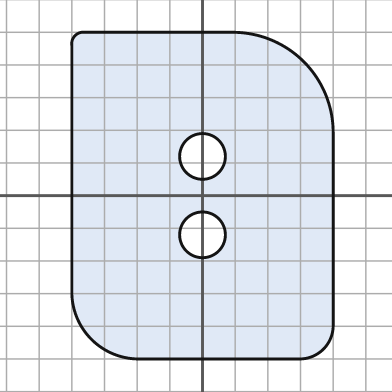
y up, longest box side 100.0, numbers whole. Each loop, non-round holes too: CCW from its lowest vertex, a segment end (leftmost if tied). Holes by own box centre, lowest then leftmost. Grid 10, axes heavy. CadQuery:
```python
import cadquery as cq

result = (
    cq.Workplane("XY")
    .moveTo(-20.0, -50.0)
    .lineTo(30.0, -50.0)
    .threePointArc((37.0, -47.0), (40.0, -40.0))
    .lineTo(40.0, 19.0)
    .threePointArc((31.0, 41.0), (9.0, 50.0))
    .lineTo(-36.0, 50.0)
    .threePointArc((-39.0, 49.0), (-40.0, 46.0))
    .lineTo(-40.0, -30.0)
    .threePointArc((-34.0, -44.0), (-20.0, -50.0))
    .close()
    .moveTo(0.0, -12.0)
    .circle(7.0)
    .moveTo(0.0, 12.0)
    .circle(7.0)
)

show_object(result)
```